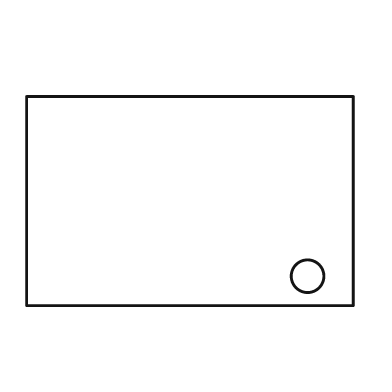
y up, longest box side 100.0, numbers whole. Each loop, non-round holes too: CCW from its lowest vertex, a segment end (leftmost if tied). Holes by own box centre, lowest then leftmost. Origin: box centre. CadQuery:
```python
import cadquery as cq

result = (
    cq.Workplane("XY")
    .moveTo(-50.0, -32.0)
    .lineTo(50.0, -32.0)
    .lineTo(50.0, 32.0)
    .lineTo(-50.0, 32.0)
    .close()
    .moveTo(36.0, -23.0)
    .circle(5.0)
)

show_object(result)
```